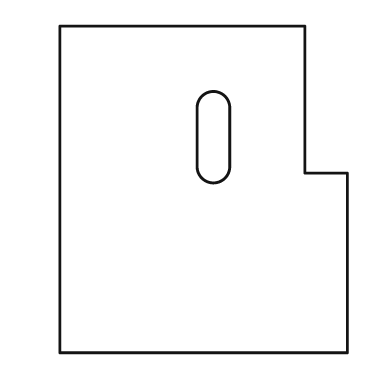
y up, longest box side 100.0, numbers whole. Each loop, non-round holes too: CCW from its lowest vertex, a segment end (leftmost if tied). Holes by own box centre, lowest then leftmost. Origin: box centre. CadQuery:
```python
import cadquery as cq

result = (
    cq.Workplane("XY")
    .moveTo(-44.0, -50.0)
    .lineTo(44.0, -50.0)
    .lineTo(44.0, 5.0)
    .lineTo(31.0, 5.0)
    .lineTo(31.0, 50.0)
    .lineTo(-44.0, 50.0)
    .close()
    .moveTo(-2.0, 7.0)
    .threePointArc((3.0, 2.0), (8.0, 7.0))
    .lineTo(8.0, 25.0)
    .threePointArc((3.0, 30.0), (-2.0, 25.0))
    .close()
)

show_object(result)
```